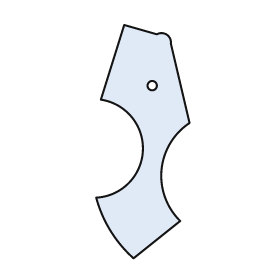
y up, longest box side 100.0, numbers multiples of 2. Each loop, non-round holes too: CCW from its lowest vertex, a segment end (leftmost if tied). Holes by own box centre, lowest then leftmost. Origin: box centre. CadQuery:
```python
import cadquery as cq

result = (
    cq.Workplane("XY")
    .moveTo(-4.0, -50.0)
    .lineTo(16.0, -34.0)
    .threePointArc((8.0, -12.0), (20.0, 8.0))
    .lineTo(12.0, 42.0)
    .threePointArc((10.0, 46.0), (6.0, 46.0))
    .lineTo(-8.0, 50.0)
    .lineTo(-18.0, 18.0)
    .threePointArc((0.0, -4.0), (-20.0, -24.0))
    .threePointArc((-14.0, -38.0), (-4.0, -50.0))
    .close()
    .moveTo(4.0, 24.0)
    .circle(2.0)
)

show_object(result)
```